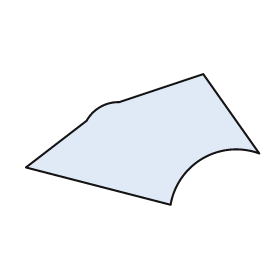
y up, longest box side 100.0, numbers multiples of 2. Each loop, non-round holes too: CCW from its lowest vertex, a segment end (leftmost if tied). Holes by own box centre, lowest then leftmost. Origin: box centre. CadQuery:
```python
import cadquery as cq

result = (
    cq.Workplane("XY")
    .moveTo(12.0, -28.0)
    .threePointArc((26.0, -8.0), (50.0, -6.0))
    .lineTo(26.0, 28.0)
    .lineTo(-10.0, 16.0)
    .threePointArc((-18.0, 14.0), (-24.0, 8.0))
    .lineTo(-50.0, -12.0)
    .close()
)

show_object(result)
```